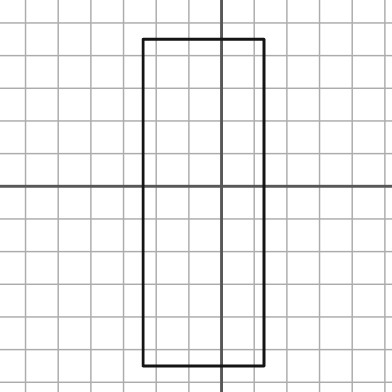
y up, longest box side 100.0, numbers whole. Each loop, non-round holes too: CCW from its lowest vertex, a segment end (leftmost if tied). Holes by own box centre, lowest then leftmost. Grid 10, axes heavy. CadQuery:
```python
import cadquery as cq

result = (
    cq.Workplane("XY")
    .moveTo(-24.0, -55.0)
    .lineTo(13.0, -55.0)
    .lineTo(13.0, 45.0)
    .lineTo(-24.0, 45.0)
    .close()
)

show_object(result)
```